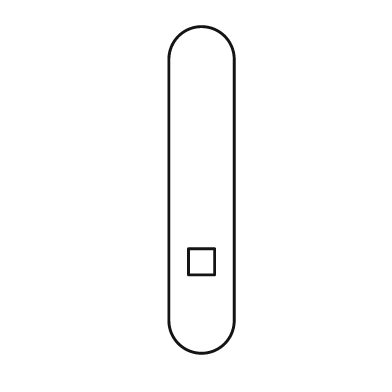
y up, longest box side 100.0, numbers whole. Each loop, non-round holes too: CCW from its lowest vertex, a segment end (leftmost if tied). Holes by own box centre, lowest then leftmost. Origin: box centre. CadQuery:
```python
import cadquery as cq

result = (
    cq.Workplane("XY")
    .moveTo(-10.0, -40.0)
    .threePointArc((0.0, -50.0), (10.0, -40.0))
    .lineTo(10.0, 40.0)
    .threePointArc((0.0, 50.0), (-10.0, 40.0))
    .close()
    .moveTo(-4.0, -26.0)
    .lineTo(4.0, -26.0)
    .lineTo(4.0, -18.0)
    .lineTo(-4.0, -18.0)
    .close()
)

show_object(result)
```